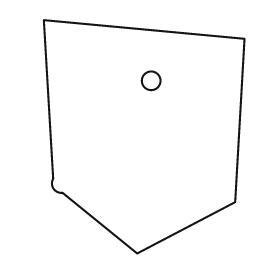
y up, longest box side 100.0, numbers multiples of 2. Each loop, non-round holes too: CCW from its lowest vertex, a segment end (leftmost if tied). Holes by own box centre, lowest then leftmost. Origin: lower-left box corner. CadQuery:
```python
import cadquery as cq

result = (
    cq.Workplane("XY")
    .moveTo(40.0, 0.0)
    .lineTo(82.0, 22.0)
    .lineTo(86.0, 92.0)
    .lineTo(0.0, 100.0)
    .lineTo(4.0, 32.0)
    .threePointArc((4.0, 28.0), (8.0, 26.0))
    .close()
    .moveTo(46.0, 74.0)
    .circle(4.0)
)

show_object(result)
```